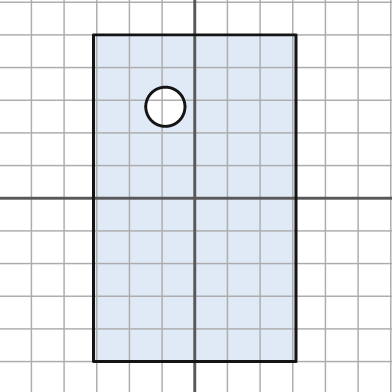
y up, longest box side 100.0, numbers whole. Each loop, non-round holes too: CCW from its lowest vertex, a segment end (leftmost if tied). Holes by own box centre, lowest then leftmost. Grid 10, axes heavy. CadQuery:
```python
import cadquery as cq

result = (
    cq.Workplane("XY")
    .moveTo(-31.0, -50.0)
    .lineTo(31.0, -50.0)
    .lineTo(31.0, 50.0)
    .lineTo(-31.0, 50.0)
    .close()
    .moveTo(-9.0, 28.0)
    .circle(6.0)
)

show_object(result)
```